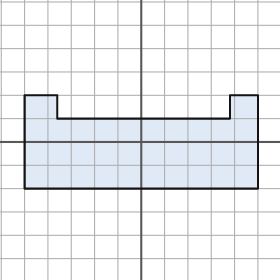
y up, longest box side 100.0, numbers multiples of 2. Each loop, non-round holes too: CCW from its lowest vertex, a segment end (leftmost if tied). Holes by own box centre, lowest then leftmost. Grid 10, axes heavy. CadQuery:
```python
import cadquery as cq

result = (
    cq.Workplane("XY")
    .moveTo(-50.0, -20.0)
    .lineTo(50.0, -20.0)
    .lineTo(50.0, 20.0)
    .lineTo(38.0, 20.0)
    .lineTo(38.0, 10.0)
    .lineTo(-36.0, 10.0)
    .lineTo(-36.0, 20.0)
    .lineTo(-50.0, 20.0)
    .close()
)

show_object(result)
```